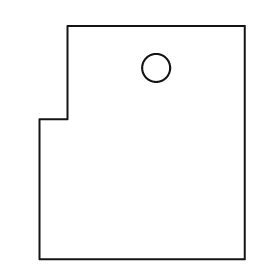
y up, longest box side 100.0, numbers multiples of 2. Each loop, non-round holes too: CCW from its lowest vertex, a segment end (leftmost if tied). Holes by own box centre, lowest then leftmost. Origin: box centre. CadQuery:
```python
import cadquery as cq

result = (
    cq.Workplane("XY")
    .moveTo(-44.0, -50.0)
    .lineTo(44.0, -50.0)
    .lineTo(44.0, 50.0)
    .lineTo(-32.0, 50.0)
    .lineTo(-32.0, 10.0)
    .lineTo(-44.0, 10.0)
    .close()
    .moveTo(6.0, 32.0)
    .circle(6.0)
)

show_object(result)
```